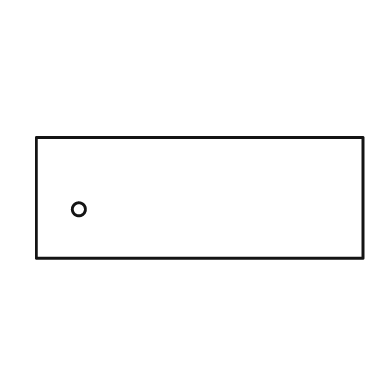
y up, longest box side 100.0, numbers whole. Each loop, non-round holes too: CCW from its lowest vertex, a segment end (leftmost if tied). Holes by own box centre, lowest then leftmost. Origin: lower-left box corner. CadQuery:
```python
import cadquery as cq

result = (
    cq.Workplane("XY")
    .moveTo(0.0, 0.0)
    .lineTo(100.0, 0.0)
    .lineTo(100.0, 37.0)
    .lineTo(0.0, 37.0)
    .close()
    .moveTo(13.0, 15.0)
    .circle(2.0)
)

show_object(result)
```